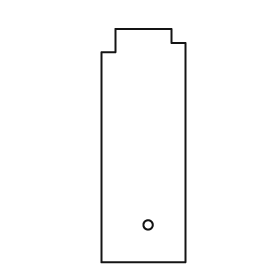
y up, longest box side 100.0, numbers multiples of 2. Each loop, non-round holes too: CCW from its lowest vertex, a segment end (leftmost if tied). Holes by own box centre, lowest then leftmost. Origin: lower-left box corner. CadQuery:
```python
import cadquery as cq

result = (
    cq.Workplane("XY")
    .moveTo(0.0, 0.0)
    .lineTo(36.0, 0.0)
    .lineTo(36.0, 94.0)
    .lineTo(30.0, 94.0)
    .lineTo(30.0, 100.0)
    .lineTo(6.0, 100.0)
    .lineTo(6.0, 90.0)
    .lineTo(0.0, 90.0)
    .close()
    .moveTo(20.0, 16.0)
    .circle(2.0)
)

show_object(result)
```